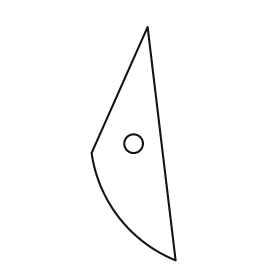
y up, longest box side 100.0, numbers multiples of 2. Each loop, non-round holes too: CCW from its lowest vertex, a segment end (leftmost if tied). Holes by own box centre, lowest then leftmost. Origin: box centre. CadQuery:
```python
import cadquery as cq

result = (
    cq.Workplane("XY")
    .moveTo(18.0, -50.0)
    .lineTo(6.0, 50.0)
    .lineTo(-18.0, -4.0)
    .threePointArc((-6.0, -32.0), (18.0, -50.0))
    .close()
    .moveTo(0.0, 0.0)
    .circle(4.0)
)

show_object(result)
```